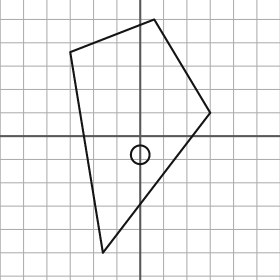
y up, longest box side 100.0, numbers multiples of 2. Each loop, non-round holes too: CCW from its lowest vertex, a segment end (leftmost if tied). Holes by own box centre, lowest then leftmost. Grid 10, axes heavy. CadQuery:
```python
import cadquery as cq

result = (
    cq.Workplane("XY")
    .moveTo(-16.0, -50.0)
    .lineTo(30.0, 10.0)
    .lineTo(6.0, 50.0)
    .lineTo(-30.0, 36.0)
    .close()
    .moveTo(0.0, -8.0)
    .circle(4.0)
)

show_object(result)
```